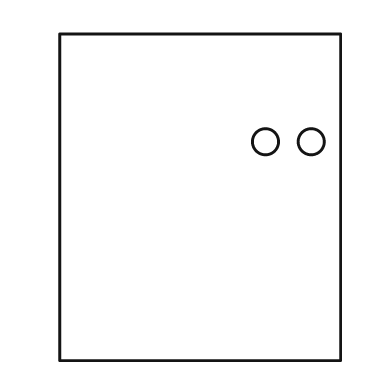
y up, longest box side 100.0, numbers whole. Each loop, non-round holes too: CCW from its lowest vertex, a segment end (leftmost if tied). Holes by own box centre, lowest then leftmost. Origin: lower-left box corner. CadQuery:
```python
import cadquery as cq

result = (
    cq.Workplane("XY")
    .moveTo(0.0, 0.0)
    .lineTo(86.0, 0.0)
    .lineTo(86.0, 100.0)
    .lineTo(0.0, 100.0)
    .close()
    .moveTo(63.0, 67.0)
    .circle(4.0)
    .moveTo(77.0, 67.0)
    .circle(4.0)
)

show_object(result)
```